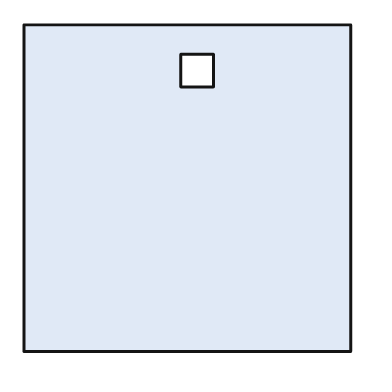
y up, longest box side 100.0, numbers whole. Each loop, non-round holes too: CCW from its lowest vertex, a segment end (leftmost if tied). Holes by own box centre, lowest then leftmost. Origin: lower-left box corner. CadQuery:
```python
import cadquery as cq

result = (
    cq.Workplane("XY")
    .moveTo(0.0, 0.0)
    .lineTo(100.0, 0.0)
    .lineTo(100.0, 100.0)
    .lineTo(0.0, 100.0)
    .close()
    .moveTo(48.0, 81.0)
    .lineTo(58.0, 81.0)
    .lineTo(58.0, 91.0)
    .lineTo(48.0, 91.0)
    .close()
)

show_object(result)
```